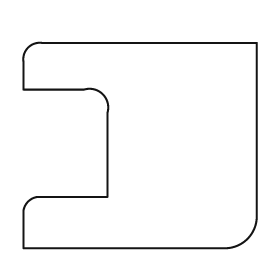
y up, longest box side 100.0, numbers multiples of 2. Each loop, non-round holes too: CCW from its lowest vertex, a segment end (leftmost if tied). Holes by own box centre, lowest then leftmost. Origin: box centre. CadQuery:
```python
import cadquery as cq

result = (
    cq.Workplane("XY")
    .moveTo(-50.0, -44.0)
    .lineTo(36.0, -44.0)
    .threePointArc((46.0, -40.0), (50.0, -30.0))
    .lineTo(50.0, 44.0)
    .lineTo(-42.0, 44.0)
    .threePointArc((-48.0, 42.0), (-50.0, 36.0))
    .lineTo(-50.0, 24.0)
    .lineTo(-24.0, 24.0)
    .threePointArc((-16.0, 22.0), (-14.0, 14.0))
    .lineTo(-14.0, -22.0)
    .lineTo(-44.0, -22.0)
    .threePointArc((-48.0, -24.0), (-50.0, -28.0))
    .close()
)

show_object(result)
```